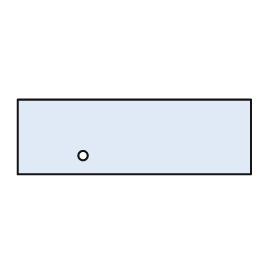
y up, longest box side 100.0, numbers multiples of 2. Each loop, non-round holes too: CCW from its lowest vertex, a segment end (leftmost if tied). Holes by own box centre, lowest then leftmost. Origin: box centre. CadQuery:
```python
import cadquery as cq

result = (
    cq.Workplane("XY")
    .moveTo(-50.0, -16.0)
    .lineTo(50.0, -16.0)
    .lineTo(50.0, 16.0)
    .lineTo(-50.0, 16.0)
    .close()
    .moveTo(-22.0, -8.0)
    .circle(2.0)
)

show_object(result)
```